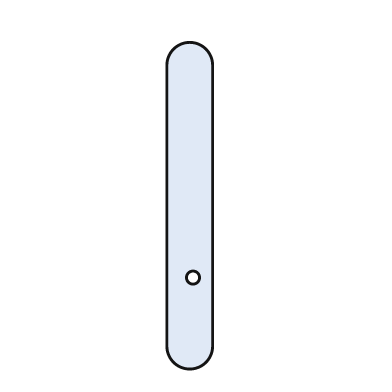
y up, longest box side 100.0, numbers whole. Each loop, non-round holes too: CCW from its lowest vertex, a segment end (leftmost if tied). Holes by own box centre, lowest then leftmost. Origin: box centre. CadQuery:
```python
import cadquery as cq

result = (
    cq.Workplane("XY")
    .moveTo(-7.0, -43.0)
    .threePointArc((0.0, -50.0), (7.0, -43.0))
    .lineTo(7.0, 43.0)
    .threePointArc((0.0, 50.0), (-7.0, 43.0))
    .close()
    .moveTo(1.0, -22.0)
    .circle(2.0)
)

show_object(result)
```